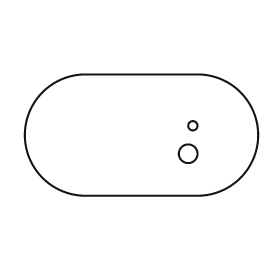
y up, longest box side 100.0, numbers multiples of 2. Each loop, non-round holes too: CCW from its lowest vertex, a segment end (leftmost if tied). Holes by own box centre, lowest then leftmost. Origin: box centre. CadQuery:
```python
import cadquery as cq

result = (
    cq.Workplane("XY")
    .moveTo(-24.0, -26.0)
    .lineTo(24.0, -26.0)
    .threePointArc((50.0, 0.0), (24.0, 26.0))
    .lineTo(-24.0, 26.0)
    .threePointArc((-50.0, 0.0), (-24.0, -26.0))
    .close()
    .moveTo(20.0, -8.0)
    .circle(4.0)
    .moveTo(22.0, 4.0)
    .circle(2.0)
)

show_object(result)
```